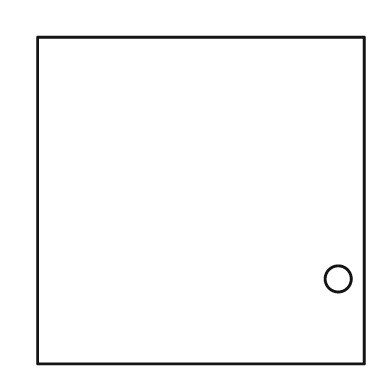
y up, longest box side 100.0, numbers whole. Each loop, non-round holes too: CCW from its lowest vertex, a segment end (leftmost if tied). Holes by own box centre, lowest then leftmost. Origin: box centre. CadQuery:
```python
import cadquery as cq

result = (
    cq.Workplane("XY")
    .moveTo(-50.0, -50.0)
    .lineTo(50.0, -50.0)
    .lineTo(50.0, 50.0)
    .lineTo(-50.0, 50.0)
    .close()
    .moveTo(42.0, -24.0)
    .circle(4.0)
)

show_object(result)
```